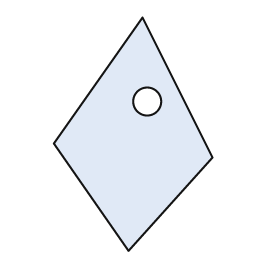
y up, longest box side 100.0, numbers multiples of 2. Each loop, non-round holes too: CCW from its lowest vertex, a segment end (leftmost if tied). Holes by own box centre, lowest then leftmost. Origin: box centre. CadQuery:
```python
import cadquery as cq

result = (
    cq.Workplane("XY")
    .moveTo(-2.0, -50.0)
    .lineTo(34.0, -10.0)
    .lineTo(4.0, 50.0)
    .lineTo(-34.0, -4.0)
    .close()
    .moveTo(6.0, 14.0)
    .circle(6.0)
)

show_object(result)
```